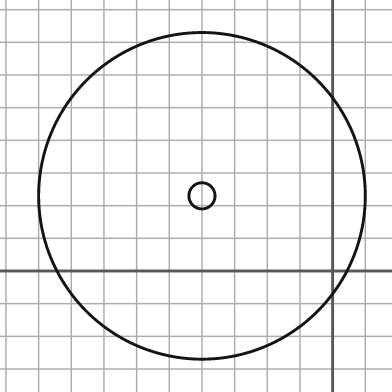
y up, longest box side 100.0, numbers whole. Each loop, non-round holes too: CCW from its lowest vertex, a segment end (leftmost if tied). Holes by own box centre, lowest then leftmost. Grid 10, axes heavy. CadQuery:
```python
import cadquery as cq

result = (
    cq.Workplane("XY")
    .moveTo(-40.0, 23.0)
    .circle(50.0)
    .moveTo(-40.0, 23.0)
    .circle(4.0)
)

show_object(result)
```